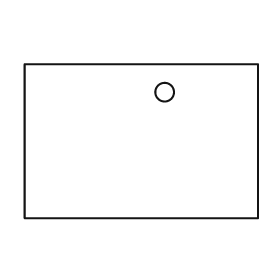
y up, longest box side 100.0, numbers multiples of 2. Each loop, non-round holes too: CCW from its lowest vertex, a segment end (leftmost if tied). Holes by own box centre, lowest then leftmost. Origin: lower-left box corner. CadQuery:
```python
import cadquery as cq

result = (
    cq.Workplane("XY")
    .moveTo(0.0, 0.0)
    .lineTo(100.0, 0.0)
    .lineTo(100.0, 66.0)
    .lineTo(0.0, 66.0)
    .close()
    .moveTo(60.0, 54.0)
    .circle(4.0)
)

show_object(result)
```